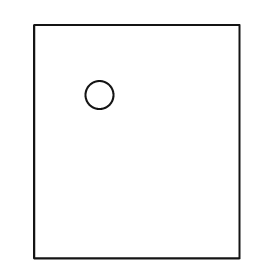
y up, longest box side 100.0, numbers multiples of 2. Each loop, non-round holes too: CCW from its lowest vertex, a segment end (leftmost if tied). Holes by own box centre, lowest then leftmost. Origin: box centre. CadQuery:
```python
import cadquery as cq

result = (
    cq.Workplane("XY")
    .moveTo(-44.0, -50.0)
    .lineTo(44.0, -50.0)
    .lineTo(44.0, 50.0)
    .lineTo(-44.0, 50.0)
    .close()
    .moveTo(-16.0, 20.0)
    .circle(6.0)
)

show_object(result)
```